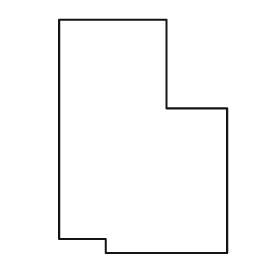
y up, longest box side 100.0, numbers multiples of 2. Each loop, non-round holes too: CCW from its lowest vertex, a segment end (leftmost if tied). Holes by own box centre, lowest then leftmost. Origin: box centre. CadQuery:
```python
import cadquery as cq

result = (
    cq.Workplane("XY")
    .moveTo(-16.0, -50.0)
    .lineTo(36.0, -50.0)
    .lineTo(36.0, 12.0)
    .lineTo(10.0, 12.0)
    .lineTo(10.0, 50.0)
    .lineTo(-36.0, 50.0)
    .lineTo(-36.0, -44.0)
    .lineTo(-16.0, -44.0)
    .close()
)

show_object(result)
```